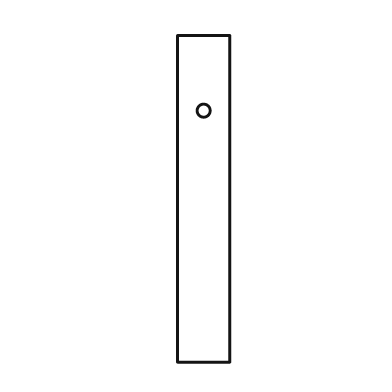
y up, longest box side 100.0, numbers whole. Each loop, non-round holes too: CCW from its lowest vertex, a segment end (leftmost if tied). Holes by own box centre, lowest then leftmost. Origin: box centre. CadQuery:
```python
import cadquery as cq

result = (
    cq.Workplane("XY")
    .moveTo(-8.0, -50.0)
    .lineTo(8.0, -50.0)
    .lineTo(8.0, 50.0)
    .lineTo(-8.0, 50.0)
    .close()
    .moveTo(0.0, 27.0)
    .circle(2.0)
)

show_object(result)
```